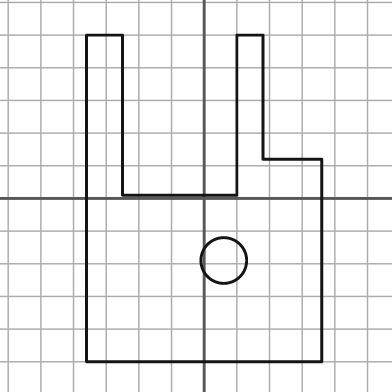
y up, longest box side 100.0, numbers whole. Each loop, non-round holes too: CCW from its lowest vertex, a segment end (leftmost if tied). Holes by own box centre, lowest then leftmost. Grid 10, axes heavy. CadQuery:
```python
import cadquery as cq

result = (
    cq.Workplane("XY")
    .moveTo(-36.0, -50.0)
    .lineTo(36.0, -50.0)
    .lineTo(36.0, 12.0)
    .lineTo(18.0, 12.0)
    .lineTo(18.0, 50.0)
    .lineTo(10.0, 50.0)
    .lineTo(10.0, 1.0)
    .lineTo(-25.0, 1.0)
    .lineTo(-25.0, 50.0)
    .lineTo(-36.0, 50.0)
    .close()
    .moveTo(6.0, -19.0)
    .circle(7.0)
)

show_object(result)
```